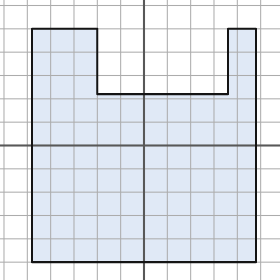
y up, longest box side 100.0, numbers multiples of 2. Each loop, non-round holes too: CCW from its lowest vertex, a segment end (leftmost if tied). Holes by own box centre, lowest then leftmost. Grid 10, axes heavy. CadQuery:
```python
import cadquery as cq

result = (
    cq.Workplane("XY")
    .moveTo(-48.0, -50.0)
    .lineTo(48.0, -50.0)
    .lineTo(48.0, 50.0)
    .lineTo(36.0, 50.0)
    .lineTo(36.0, 22.0)
    .lineTo(-20.0, 22.0)
    .lineTo(-20.0, 50.0)
    .lineTo(-48.0, 50.0)
    .close()
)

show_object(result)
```